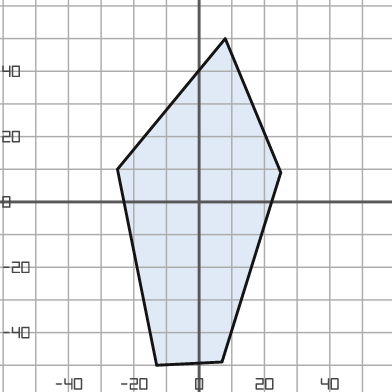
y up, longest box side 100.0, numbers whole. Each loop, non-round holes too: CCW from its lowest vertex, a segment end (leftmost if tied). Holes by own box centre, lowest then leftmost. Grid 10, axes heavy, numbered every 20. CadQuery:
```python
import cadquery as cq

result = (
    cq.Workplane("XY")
    .moveTo(-13.0, -50.0)
    .lineTo(7.0, -49.0)
    .lineTo(25.0, 9.0)
    .lineTo(8.0, 50.0)
    .lineTo(-25.0, 10.0)
    .close()
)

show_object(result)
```